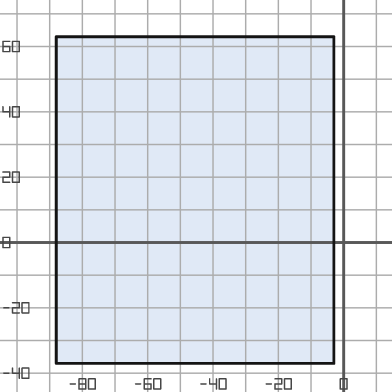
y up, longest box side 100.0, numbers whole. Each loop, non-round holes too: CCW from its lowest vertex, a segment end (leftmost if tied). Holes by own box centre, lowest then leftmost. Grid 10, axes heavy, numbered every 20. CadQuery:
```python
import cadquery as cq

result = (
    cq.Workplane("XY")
    .moveTo(-88.0, -37.0)
    .lineTo(-3.0, -37.0)
    .lineTo(-3.0, 63.0)
    .lineTo(-88.0, 63.0)
    .close()
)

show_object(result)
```